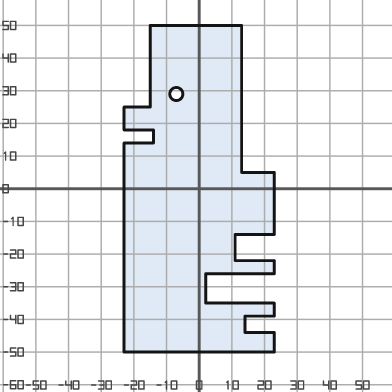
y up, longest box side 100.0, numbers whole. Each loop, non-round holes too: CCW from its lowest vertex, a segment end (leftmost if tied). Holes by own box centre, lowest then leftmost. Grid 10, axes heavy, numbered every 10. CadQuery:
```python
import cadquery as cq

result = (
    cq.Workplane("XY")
    .moveTo(-23.0, -50.0)
    .lineTo(23.0, -50.0)
    .lineTo(23.0, -44.0)
    .lineTo(14.0, -44.0)
    .lineTo(14.0, -39.0)
    .lineTo(23.0, -39.0)
    .lineTo(23.0, -35.0)
    .lineTo(2.0, -35.0)
    .lineTo(2.0, -26.0)
    .lineTo(23.0, -26.0)
    .lineTo(23.0, -22.0)
    .lineTo(11.0, -22.0)
    .lineTo(11.0, -14.0)
    .lineTo(23.0, -14.0)
    .lineTo(23.0, 5.0)
    .lineTo(13.0, 5.0)
    .lineTo(13.0, 50.0)
    .lineTo(-15.0, 50.0)
    .lineTo(-15.0, 25.0)
    .lineTo(-23.0, 25.0)
    .lineTo(-23.0, 18.0)
    .lineTo(-14.0, 18.0)
    .lineTo(-14.0, 14.0)
    .lineTo(-23.0, 14.0)
    .close()
    .moveTo(-7.0, 29.0)
    .circle(2.0)
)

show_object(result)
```